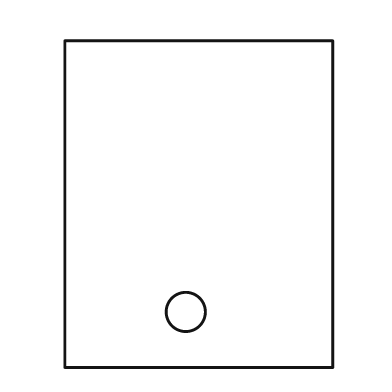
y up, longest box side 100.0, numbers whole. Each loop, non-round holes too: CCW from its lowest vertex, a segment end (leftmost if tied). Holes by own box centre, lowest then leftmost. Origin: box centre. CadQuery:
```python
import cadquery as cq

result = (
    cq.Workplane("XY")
    .moveTo(-41.0, -50.0)
    .lineTo(41.0, -50.0)
    .lineTo(41.0, 50.0)
    .lineTo(-41.0, 50.0)
    .close()
    .moveTo(-4.0, -33.0)
    .circle(6.0)
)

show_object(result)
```